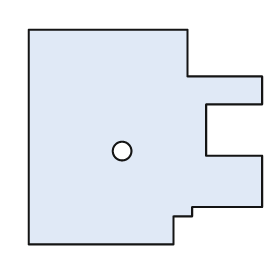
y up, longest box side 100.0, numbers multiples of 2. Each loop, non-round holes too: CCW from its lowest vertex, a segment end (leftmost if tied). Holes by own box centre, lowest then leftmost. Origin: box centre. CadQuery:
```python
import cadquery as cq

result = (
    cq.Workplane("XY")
    .moveTo(-50.0, -46.0)
    .lineTo(12.0, -46.0)
    .lineTo(12.0, -34.0)
    .lineTo(20.0, -34.0)
    .lineTo(20.0, -30.0)
    .lineTo(50.0, -30.0)
    .lineTo(50.0, -8.0)
    .lineTo(26.0, -8.0)
    .lineTo(26.0, 14.0)
    .lineTo(50.0, 14.0)
    .lineTo(50.0, 26.0)
    .lineTo(18.0, 26.0)
    .lineTo(18.0, 46.0)
    .lineTo(-50.0, 46.0)
    .close()
    .moveTo(-10.0, -6.0)
    .circle(4.0)
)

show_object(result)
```